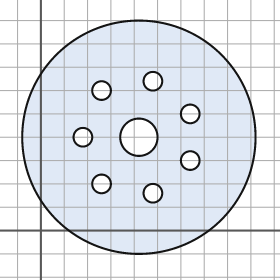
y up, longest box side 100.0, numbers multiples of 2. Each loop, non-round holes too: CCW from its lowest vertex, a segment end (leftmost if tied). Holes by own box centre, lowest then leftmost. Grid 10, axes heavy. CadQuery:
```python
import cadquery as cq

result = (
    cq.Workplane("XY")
    .moveTo(42.0, 40.0)
    .circle(50.0)
    .moveTo(48.0, 16.0)
    .circle(4.0)
    .moveTo(26.0, 20.0)
    .circle(4.0)
    .moveTo(64.0, 30.0)
    .circle(4.0)
    .moveTo(18.0, 40.0)
    .circle(4.0)
    .moveTo(42.0, 40.0)
    .circle(8.0)
    .moveTo(64.0, 50.0)
    .circle(4.0)
    .moveTo(26.0, 60.0)
    .circle(4.0)
    .moveTo(48.0, 64.0)
    .circle(4.0)
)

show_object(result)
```